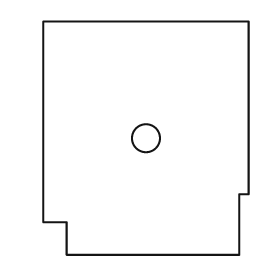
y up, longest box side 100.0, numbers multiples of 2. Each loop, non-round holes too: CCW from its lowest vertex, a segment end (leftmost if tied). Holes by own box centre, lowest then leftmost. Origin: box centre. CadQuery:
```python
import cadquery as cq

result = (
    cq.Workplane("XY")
    .moveTo(-34.0, -50.0)
    .lineTo(40.0, -50.0)
    .lineTo(40.0, -24.0)
    .lineTo(44.0, -24.0)
    .lineTo(44.0, 50.0)
    .lineTo(-44.0, 50.0)
    .lineTo(-44.0, -36.0)
    .lineTo(-34.0, -36.0)
    .close()
    .moveTo(0.0, 0.0)
    .circle(6.0)
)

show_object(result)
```